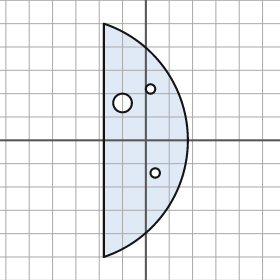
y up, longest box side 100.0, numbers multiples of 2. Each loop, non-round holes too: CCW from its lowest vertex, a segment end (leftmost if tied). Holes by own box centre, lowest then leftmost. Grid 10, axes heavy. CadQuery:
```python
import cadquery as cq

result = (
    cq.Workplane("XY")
    .moveTo(-18.0, -50.0)
    .threePointArc((18.0, 0.0), (-18.0, 50.0))
    .close()
    .moveTo(4.0, -14.0)
    .circle(2.0)
    .moveTo(-10.0, 16.0)
    .circle(4.0)
    .moveTo(2.0, 22.0)
    .circle(2.0)
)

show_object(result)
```